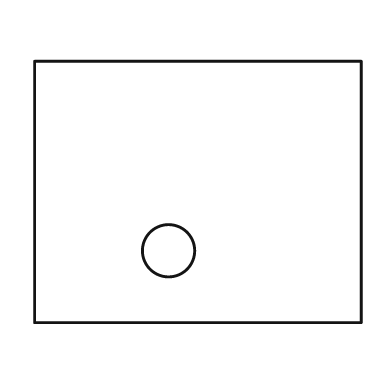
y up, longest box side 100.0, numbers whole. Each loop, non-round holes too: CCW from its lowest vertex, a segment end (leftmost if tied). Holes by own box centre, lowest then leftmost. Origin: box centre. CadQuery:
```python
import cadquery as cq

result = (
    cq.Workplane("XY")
    .moveTo(-50.0, -40.0)
    .lineTo(50.0, -40.0)
    .lineTo(50.0, 40.0)
    .lineTo(-50.0, 40.0)
    .close()
    .moveTo(-9.0, -18.0)
    .circle(8.0)
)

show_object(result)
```